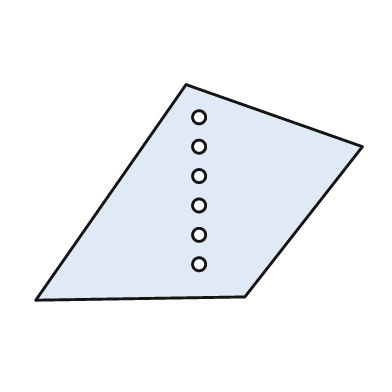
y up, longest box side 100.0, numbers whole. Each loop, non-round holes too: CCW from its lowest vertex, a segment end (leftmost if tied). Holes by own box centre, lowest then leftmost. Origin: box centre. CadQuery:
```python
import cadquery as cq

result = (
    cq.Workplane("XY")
    .moveTo(-50.0, -33.0)
    .lineTo(14.0, -32.0)
    .lineTo(50.0, 14.0)
    .lineTo(-4.0, 33.0)
    .close()
    .moveTo(0.0, -22.0)
    .circle(2.0)
    .moveTo(0.0, -13.0)
    .circle(2.0)
    .moveTo(0.0, -4.0)
    .circle(2.0)
    .moveTo(0.0, 5.0)
    .circle(2.0)
    .moveTo(0.0, 14.0)
    .circle(2.0)
    .moveTo(0.0, 23.0)
    .circle(2.0)
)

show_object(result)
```